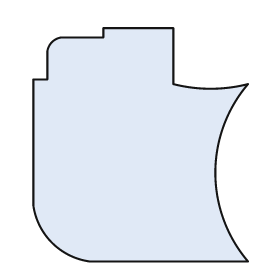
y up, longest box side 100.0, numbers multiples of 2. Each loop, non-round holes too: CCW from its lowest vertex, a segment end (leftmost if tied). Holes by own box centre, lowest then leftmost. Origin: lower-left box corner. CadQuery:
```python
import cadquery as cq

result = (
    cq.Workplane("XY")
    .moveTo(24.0, 0.0)
    .lineTo(92.0, 0.0)
    .threePointArc((78.0, 38.0), (92.0, 76.0))
    .threePointArc((76.0, 74.0), (60.0, 76.0))
    .lineTo(60.0, 100.0)
    .lineTo(30.0, 100.0)
    .lineTo(30.0, 96.0)
    .lineTo(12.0, 96.0)
    .threePointArc((8.0, 94.0), (6.0, 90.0))
    .lineTo(6.0, 78.0)
    .lineTo(0.0, 78.0)
    .lineTo(0.0, 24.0)
    .threePointArc((8.0, 8.0), (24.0, 0.0))
    .close()
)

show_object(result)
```